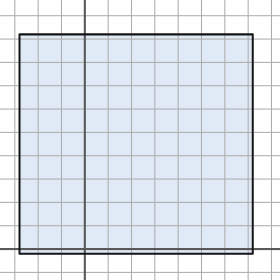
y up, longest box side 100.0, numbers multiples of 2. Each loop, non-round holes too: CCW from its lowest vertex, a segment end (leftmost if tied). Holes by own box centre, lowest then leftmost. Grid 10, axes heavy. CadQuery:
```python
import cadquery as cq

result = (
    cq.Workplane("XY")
    .moveTo(-28.0, -2.0)
    .lineTo(72.0, -2.0)
    .lineTo(72.0, 92.0)
    .lineTo(-28.0, 92.0)
    .close()
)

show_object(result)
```